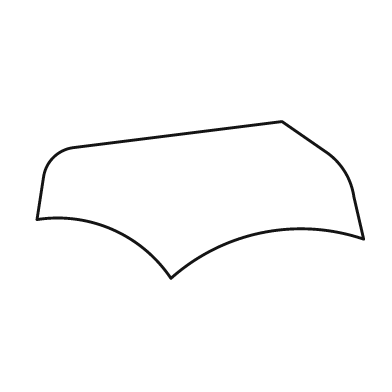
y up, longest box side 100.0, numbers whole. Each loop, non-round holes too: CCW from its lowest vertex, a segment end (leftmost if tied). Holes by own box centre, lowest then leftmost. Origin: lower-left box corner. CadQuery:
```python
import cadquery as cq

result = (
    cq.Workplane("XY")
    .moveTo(41.0, 0.0)
    .threePointArc((69.0, 14.0), (100.0, 12.0))
    .lineTo(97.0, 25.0)
    .threePointArc((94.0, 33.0), (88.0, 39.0))
    .lineTo(75.0, 48.0)
    .lineTo(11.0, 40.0)
    .threePointArc((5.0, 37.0), (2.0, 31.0))
    .lineTo(0.0, 18.0)
    .threePointArc((23.0, 15.0), (41.0, 0.0))
    .close()
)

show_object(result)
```